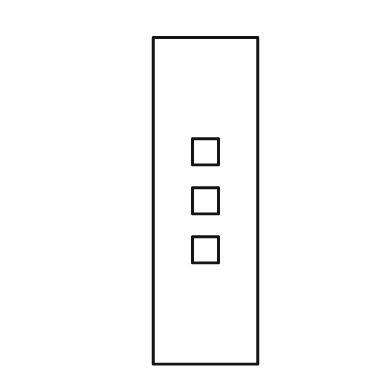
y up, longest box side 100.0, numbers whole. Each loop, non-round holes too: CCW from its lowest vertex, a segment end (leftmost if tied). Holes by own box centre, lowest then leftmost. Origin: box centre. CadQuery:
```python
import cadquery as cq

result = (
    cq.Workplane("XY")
    .moveTo(-16.0, -50.0)
    .lineTo(16.0, -50.0)
    .lineTo(16.0, 50.0)
    .lineTo(-16.0, 50.0)
    .close()
    .moveTo(-4.0, -19.0)
    .lineTo(4.0, -19.0)
    .lineTo(4.0, -11.0)
    .lineTo(-4.0, -11.0)
    .close()
    .moveTo(-4.0, -4.0)
    .lineTo(4.0, -4.0)
    .lineTo(4.0, 4.0)
    .lineTo(-4.0, 4.0)
    .close()
    .moveTo(-4.0, 11.0)
    .lineTo(4.0, 11.0)
    .lineTo(4.0, 19.0)
    .lineTo(-4.0, 19.0)
    .close()
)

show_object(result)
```